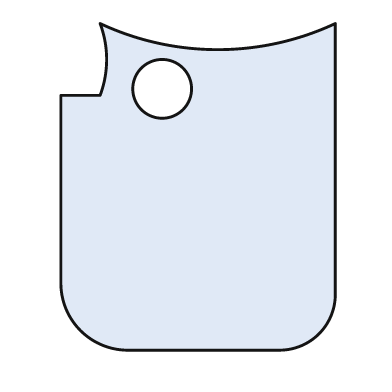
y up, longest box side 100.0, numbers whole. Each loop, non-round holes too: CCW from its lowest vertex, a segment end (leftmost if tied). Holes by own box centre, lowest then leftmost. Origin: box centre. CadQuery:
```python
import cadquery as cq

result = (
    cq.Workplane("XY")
    .moveTo(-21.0, -50.0)
    .lineTo(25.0, -50.0)
    .threePointArc((37.0, -45.0), (42.0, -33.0))
    .lineTo(42.0, 50.0)
    .threePointArc((6.0, 42.0), (-30.0, 50.0))
    .threePointArc((-28.0, 39.0), (-30.0, 28.0))
    .lineTo(-42.0, 28.0)
    .lineTo(-42.0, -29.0)
    .threePointArc((-36.0, -44.0), (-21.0, -50.0))
    .close()
    .moveTo(-11.0, 30.0)
    .circle(9.0)
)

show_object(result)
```